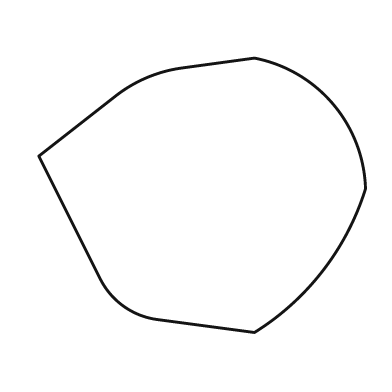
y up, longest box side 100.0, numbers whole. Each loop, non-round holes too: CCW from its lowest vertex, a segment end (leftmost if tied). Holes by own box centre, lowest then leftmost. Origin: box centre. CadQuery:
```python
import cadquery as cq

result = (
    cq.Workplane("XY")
    .moveTo(16.0, -42.0)
    .threePointArc((37.0, -23.0), (50.0, 2.0))
    .threePointArc((40.0, 28.0), (16.0, 42.0))
    .lineTo(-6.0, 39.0)
    .threePointArc((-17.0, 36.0), (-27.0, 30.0))
    .lineTo(-50.0, 12.0)
    .lineTo(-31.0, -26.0)
    .threePointArc((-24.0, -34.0), (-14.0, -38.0))
    .close()
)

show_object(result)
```